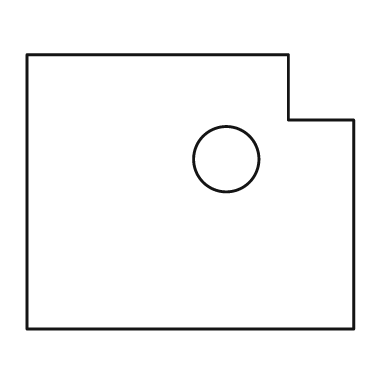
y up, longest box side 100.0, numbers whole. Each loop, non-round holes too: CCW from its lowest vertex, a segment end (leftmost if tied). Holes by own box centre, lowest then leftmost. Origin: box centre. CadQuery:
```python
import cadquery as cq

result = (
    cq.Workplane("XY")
    .moveTo(-50.0, -42.0)
    .lineTo(50.0, -42.0)
    .lineTo(50.0, 22.0)
    .lineTo(30.0, 22.0)
    .lineTo(30.0, 42.0)
    .lineTo(-50.0, 42.0)
    .close()
    .moveTo(11.0, 10.0)
    .circle(10.0)
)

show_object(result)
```